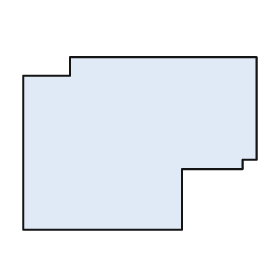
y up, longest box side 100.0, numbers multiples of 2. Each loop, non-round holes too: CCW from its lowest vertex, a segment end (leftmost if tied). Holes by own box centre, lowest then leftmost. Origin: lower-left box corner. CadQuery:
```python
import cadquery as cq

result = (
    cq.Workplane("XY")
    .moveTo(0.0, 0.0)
    .lineTo(68.0, 0.0)
    .lineTo(68.0, 26.0)
    .lineTo(94.0, 26.0)
    .lineTo(94.0, 30.0)
    .lineTo(100.0, 30.0)
    .lineTo(100.0, 74.0)
    .lineTo(20.0, 74.0)
    .lineTo(20.0, 66.0)
    .lineTo(0.0, 66.0)
    .close()
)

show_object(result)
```